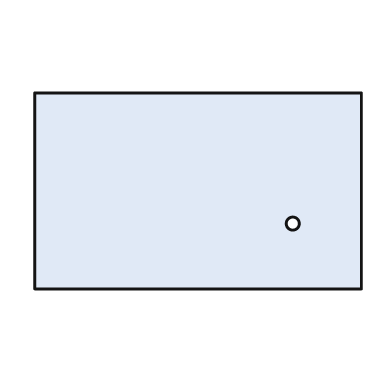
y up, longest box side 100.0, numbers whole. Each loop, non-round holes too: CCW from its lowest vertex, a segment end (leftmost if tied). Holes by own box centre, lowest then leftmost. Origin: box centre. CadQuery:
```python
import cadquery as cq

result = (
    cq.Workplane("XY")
    .moveTo(-50.0, -30.0)
    .lineTo(50.0, -30.0)
    .lineTo(50.0, 30.0)
    .lineTo(-50.0, 30.0)
    .close()
    .moveTo(29.0, -10.0)
    .circle(2.0)
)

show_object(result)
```